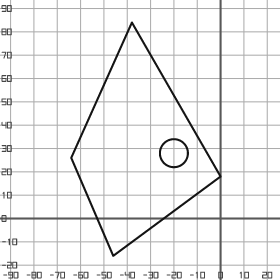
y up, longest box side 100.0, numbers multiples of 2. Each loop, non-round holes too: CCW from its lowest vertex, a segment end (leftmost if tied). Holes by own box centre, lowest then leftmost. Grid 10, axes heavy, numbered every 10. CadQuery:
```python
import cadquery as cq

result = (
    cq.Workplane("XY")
    .moveTo(-46.0, -16.0)
    .lineTo(0.0, 18.0)
    .lineTo(-38.0, 84.0)
    .lineTo(-64.0, 26.0)
    .close()
    .moveTo(-20.0, 28.0)
    .circle(6.0)
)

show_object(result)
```